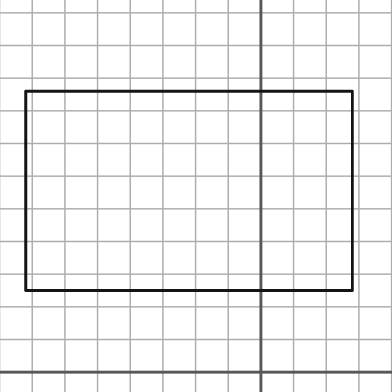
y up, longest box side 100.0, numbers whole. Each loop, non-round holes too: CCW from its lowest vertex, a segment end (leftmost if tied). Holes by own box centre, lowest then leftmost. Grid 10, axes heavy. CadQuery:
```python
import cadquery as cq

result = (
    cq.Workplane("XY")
    .moveTo(-72.0, 25.0)
    .lineTo(28.0, 25.0)
    .lineTo(28.0, 86.0)
    .lineTo(-72.0, 86.0)
    .close()
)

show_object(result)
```